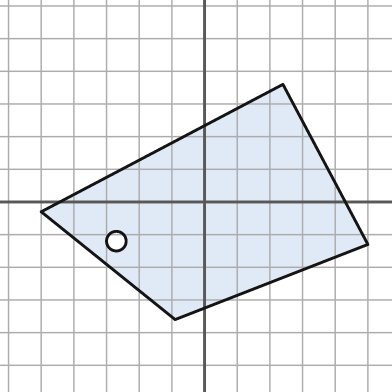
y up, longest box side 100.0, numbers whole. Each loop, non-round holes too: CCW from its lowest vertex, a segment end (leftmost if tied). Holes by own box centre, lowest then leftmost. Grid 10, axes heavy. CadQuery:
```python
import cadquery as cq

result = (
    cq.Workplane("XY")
    .moveTo(-9.0, -36.0)
    .lineTo(50.0, -13.0)
    .lineTo(24.0, 36.0)
    .lineTo(-50.0, -3.0)
    .close()
    .moveTo(-27.0, -12.0)
    .circle(3.0)
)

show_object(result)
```